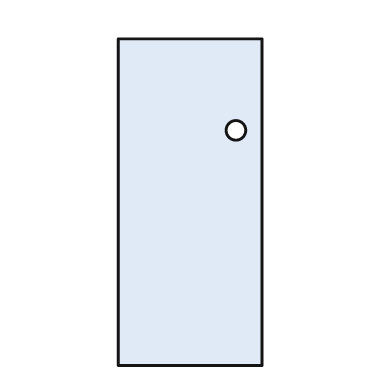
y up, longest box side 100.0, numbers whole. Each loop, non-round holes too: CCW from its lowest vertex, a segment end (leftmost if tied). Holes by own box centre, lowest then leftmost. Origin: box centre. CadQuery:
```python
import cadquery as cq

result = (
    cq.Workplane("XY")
    .moveTo(-22.0, -50.0)
    .lineTo(22.0, -50.0)
    .lineTo(22.0, 50.0)
    .lineTo(-22.0, 50.0)
    .close()
    .moveTo(14.0, 22.0)
    .circle(3.0)
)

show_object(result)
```